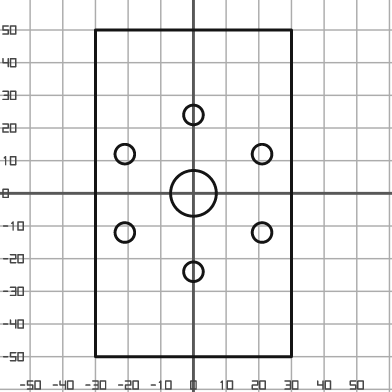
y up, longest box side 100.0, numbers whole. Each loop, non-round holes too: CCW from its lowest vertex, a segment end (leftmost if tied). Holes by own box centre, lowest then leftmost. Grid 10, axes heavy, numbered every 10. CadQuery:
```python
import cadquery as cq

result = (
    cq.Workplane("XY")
    .moveTo(-30.0, -50.0)
    .lineTo(30.0, -50.0)
    .lineTo(30.0, 50.0)
    .lineTo(-30.0, 50.0)
    .close()
    .moveTo(0.0, -24.0)
    .circle(3.0)
    .moveTo(-21.0, -12.0)
    .circle(3.0)
    .moveTo(21.0, -12.0)
    .circle(3.0)
    .moveTo(0.0, 0.0)
    .circle(7.0)
    .moveTo(-21.0, 12.0)
    .circle(3.0)
    .moveTo(21.0, 12.0)
    .circle(3.0)
    .moveTo(0.0, 24.0)
    .circle(3.0)
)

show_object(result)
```